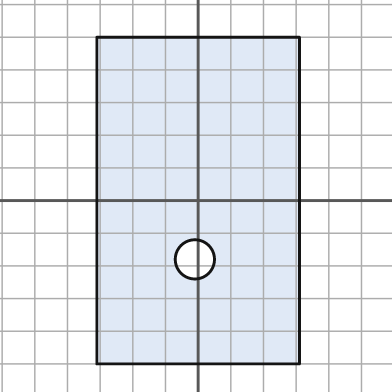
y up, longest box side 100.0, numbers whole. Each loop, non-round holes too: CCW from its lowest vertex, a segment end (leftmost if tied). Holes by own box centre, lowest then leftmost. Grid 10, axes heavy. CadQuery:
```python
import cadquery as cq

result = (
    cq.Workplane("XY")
    .moveTo(-31.0, -50.0)
    .lineTo(31.0, -50.0)
    .lineTo(31.0, 50.0)
    .lineTo(-31.0, 50.0)
    .close()
    .moveTo(-1.0, -18.0)
    .circle(6.0)
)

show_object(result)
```